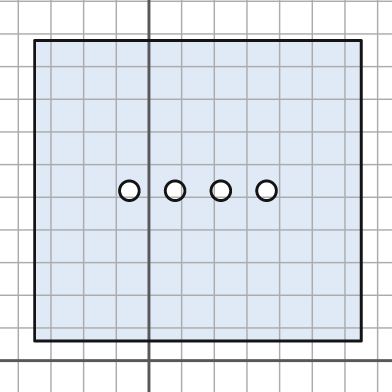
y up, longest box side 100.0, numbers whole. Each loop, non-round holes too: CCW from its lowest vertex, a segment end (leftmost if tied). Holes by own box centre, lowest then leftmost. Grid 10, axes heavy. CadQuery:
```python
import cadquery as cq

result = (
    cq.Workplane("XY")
    .moveTo(-35.0, 6.0)
    .lineTo(65.0, 6.0)
    .lineTo(65.0, 98.0)
    .lineTo(-35.0, 98.0)
    .close()
    .moveTo(-6.0, 52.0)
    .circle(3.0)
    .moveTo(8.0, 52.0)
    .circle(3.0)
    .moveTo(22.0, 52.0)
    .circle(3.0)
    .moveTo(36.0, 52.0)
    .circle(3.0)
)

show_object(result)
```